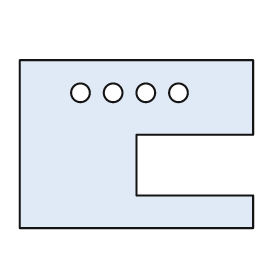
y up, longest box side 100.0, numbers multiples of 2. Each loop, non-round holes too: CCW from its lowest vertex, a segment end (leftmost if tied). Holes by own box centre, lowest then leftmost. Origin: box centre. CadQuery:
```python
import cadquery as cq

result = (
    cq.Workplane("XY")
    .moveTo(-50.0, -36.0)
    .lineTo(50.0, -36.0)
    .lineTo(50.0, -22.0)
    .lineTo(0.0, -22.0)
    .lineTo(0.0, 4.0)
    .lineTo(50.0, 4.0)
    .lineTo(50.0, 36.0)
    .lineTo(-50.0, 36.0)
    .close()
    .moveTo(-24.0, 22.0)
    .circle(4.0)
    .moveTo(-10.0, 22.0)
    .circle(4.0)
    .moveTo(4.0, 22.0)
    .circle(4.0)
    .moveTo(18.0, 22.0)
    .circle(4.0)
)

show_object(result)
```